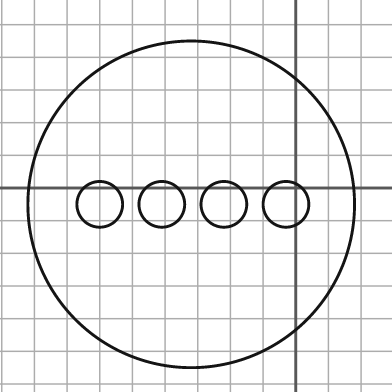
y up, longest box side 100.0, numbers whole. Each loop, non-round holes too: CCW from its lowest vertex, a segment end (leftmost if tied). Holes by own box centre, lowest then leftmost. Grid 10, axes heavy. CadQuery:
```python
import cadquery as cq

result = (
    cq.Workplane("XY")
    .moveTo(-32.0, -5.0)
    .circle(50.0)
    .moveTo(-60.0, -5.0)
    .circle(7.0)
    .moveTo(-41.0, -5.0)
    .circle(7.0)
    .moveTo(-22.0, -5.0)
    .circle(7.0)
    .moveTo(-3.0, -5.0)
    .circle(7.0)
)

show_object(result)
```